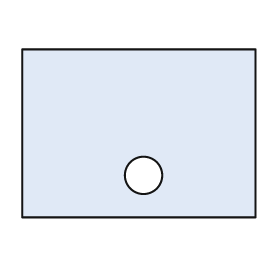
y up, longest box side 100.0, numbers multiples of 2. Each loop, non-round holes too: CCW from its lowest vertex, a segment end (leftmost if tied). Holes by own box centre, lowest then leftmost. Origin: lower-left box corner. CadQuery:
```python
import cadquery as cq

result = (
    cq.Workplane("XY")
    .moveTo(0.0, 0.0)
    .lineTo(100.0, 0.0)
    .lineTo(100.0, 72.0)
    .lineTo(0.0, 72.0)
    .close()
    .moveTo(52.0, 18.0)
    .circle(8.0)
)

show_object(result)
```